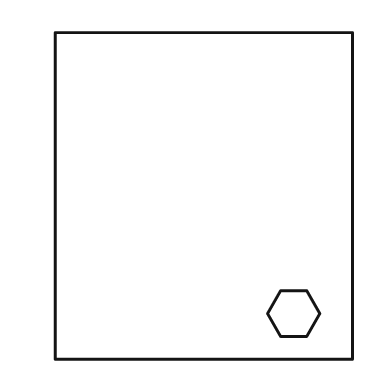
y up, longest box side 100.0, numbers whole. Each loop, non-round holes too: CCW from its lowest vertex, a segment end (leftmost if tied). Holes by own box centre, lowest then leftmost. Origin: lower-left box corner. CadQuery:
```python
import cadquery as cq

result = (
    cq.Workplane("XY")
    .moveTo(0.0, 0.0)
    .lineTo(91.0, 0.0)
    .lineTo(91.0, 100.0)
    .lineTo(0.0, 100.0)
    .close()
    .moveTo(69.0, 7.0)
    .lineTo(77.0, 7.0)
    .lineTo(81.0, 14.0)
    .lineTo(77.0, 21.0)
    .lineTo(69.0, 21.0)
    .lineTo(65.0, 14.0)
    .close()
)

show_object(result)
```